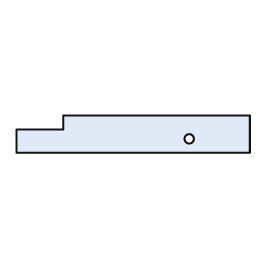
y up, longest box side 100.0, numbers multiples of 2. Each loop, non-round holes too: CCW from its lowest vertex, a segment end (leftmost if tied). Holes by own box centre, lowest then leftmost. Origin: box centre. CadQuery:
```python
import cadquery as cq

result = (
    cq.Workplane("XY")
    .moveTo(-50.0, -8.0)
    .lineTo(50.0, -8.0)
    .lineTo(50.0, 8.0)
    .lineTo(-30.0, 8.0)
    .lineTo(-30.0, 2.0)
    .lineTo(-50.0, 2.0)
    .close()
    .moveTo(24.0, -2.0)
    .circle(2.0)
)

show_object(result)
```